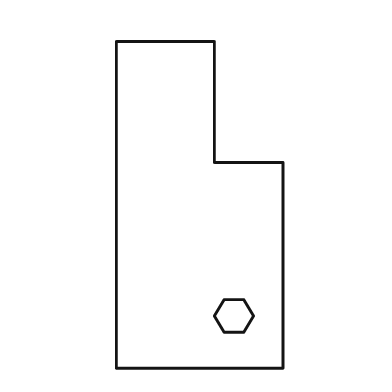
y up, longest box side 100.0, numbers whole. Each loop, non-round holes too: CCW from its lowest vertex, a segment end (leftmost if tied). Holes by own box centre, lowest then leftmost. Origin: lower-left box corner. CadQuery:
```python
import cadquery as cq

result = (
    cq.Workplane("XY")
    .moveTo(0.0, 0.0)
    .lineTo(51.0, 0.0)
    .lineTo(51.0, 63.0)
    .lineTo(30.0, 63.0)
    .lineTo(30.0, 100.0)
    .lineTo(0.0, 100.0)
    .close()
    .moveTo(33.0, 11.0)
    .lineTo(39.0, 11.0)
    .lineTo(42.0, 16.0)
    .lineTo(39.0, 21.0)
    .lineTo(33.0, 21.0)
    .lineTo(30.0, 16.0)
    .close()
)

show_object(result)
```